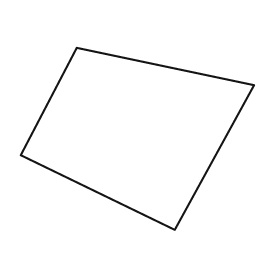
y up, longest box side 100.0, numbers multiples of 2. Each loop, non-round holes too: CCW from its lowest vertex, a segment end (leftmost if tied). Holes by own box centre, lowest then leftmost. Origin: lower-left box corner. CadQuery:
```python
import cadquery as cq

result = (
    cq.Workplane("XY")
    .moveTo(66.0, 0.0)
    .lineTo(100.0, 62.0)
    .lineTo(24.0, 78.0)
    .lineTo(0.0, 32.0)
    .close()
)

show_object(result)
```